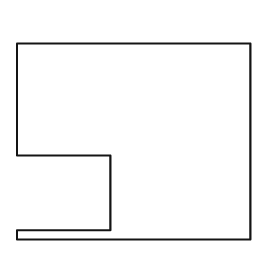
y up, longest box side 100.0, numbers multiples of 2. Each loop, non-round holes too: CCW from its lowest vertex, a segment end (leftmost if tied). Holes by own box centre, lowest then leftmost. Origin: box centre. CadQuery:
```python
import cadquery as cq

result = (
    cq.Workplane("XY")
    .moveTo(-50.0, -42.0)
    .lineTo(50.0, -42.0)
    .lineTo(50.0, 42.0)
    .lineTo(-50.0, 42.0)
    .lineTo(-50.0, -6.0)
    .lineTo(-10.0, -6.0)
    .lineTo(-10.0, -38.0)
    .lineTo(-50.0, -38.0)
    .close()
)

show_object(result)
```